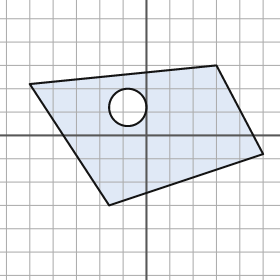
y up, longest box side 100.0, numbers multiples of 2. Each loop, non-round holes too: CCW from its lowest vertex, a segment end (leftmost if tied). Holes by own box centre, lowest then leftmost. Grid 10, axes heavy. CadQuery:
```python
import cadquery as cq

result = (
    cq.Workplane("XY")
    .moveTo(-16.0, -30.0)
    .lineTo(50.0, -8.0)
    .lineTo(30.0, 30.0)
    .lineTo(-50.0, 22.0)
    .close()
    .moveTo(-8.0, 12.0)
    .circle(8.0)
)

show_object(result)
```